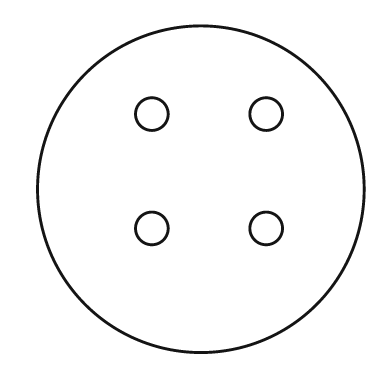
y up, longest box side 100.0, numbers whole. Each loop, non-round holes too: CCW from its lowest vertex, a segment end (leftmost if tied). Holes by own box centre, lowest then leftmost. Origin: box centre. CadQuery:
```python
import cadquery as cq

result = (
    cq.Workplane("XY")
    .moveTo(0.0, 0.0)
    .circle(50.0)
    .moveTo(-15.0, -12.0)
    .circle(5.0)
    .moveTo(20.0, -12.0)
    .circle(5.0)
    .moveTo(-15.0, 23.0)
    .circle(5.0)
    .moveTo(20.0, 23.0)
    .circle(5.0)
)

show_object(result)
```